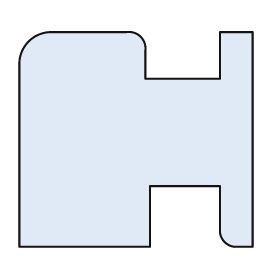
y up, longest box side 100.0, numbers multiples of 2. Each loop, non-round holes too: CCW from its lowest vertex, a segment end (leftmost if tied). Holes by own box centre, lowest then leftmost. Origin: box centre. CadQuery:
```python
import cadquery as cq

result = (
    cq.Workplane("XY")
    .moveTo(-50.0, -46.0)
    .lineTo(6.0, -46.0)
    .lineTo(6.0, -20.0)
    .lineTo(36.0, -20.0)
    .lineTo(36.0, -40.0)
    .threePointArc((38.0, -44.0), (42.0, -46.0))
    .lineTo(50.0, -46.0)
    .lineTo(50.0, 46.0)
    .lineTo(36.0, 46.0)
    .lineTo(36.0, 26.0)
    .lineTo(4.0, 26.0)
    .lineTo(4.0, 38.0)
    .threePointArc((2.0, 44.0), (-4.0, 46.0))
    .lineTo(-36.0, 46.0)
    .threePointArc((-46.0, 42.0), (-50.0, 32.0))
    .close()
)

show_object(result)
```